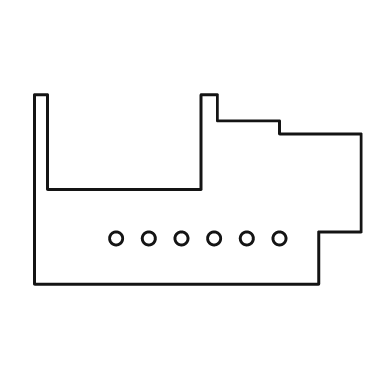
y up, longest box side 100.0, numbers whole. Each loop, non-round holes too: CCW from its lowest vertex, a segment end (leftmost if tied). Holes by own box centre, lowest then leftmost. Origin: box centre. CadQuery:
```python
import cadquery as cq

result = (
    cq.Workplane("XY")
    .moveTo(-50.0, -29.0)
    .lineTo(37.0, -29.0)
    .lineTo(37.0, -13.0)
    .lineTo(50.0, -13.0)
    .lineTo(50.0, 17.0)
    .lineTo(25.0, 17.0)
    .lineTo(25.0, 21.0)
    .lineTo(6.0, 21.0)
    .lineTo(6.0, 29.0)
    .lineTo(1.0, 29.0)
    .lineTo(1.0, 0.0)
    .lineTo(-46.0, 0.0)
    .lineTo(-46.0, 29.0)
    .lineTo(-50.0, 29.0)
    .close()
    .moveTo(-25.0, -15.0)
    .circle(2.0)
    .moveTo(-15.0, -15.0)
    .circle(2.0)
    .moveTo(-5.0, -15.0)
    .circle(2.0)
    .moveTo(5.0, -15.0)
    .circle(2.0)
    .moveTo(15.0, -15.0)
    .circle(2.0)
    .moveTo(25.0, -15.0)
    .circle(2.0)
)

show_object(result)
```